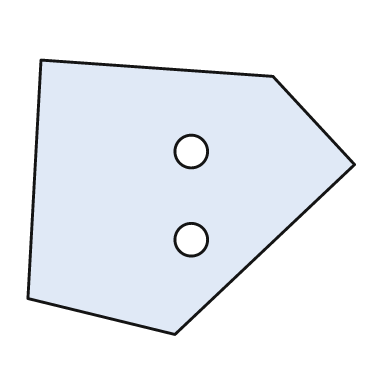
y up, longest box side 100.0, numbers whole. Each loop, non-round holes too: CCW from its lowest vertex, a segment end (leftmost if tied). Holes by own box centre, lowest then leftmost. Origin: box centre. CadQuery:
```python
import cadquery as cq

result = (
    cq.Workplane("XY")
    .moveTo(-5.0, -42.0)
    .lineTo(50.0, 10.0)
    .lineTo(25.0, 37.0)
    .lineTo(-46.0, 42.0)
    .lineTo(-50.0, -31.0)
    .close()
    .moveTo(0.0, -13.0)
    .circle(5.0)
    .moveTo(0.0, 14.0)
    .circle(5.0)
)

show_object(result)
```